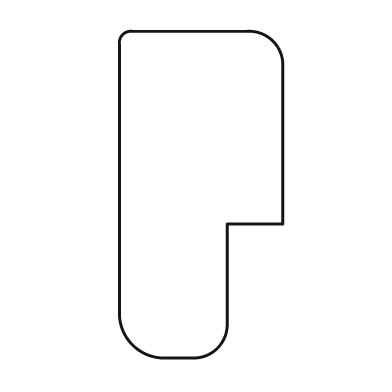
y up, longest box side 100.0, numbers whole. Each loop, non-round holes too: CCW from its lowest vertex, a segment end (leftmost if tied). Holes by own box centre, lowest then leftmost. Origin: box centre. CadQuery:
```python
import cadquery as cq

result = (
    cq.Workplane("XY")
    .moveTo(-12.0, -50.0)
    .lineTo(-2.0, -50.0)
    .threePointArc((5.0, -47.0), (8.0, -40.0))
    .lineTo(8.0, -9.0)
    .lineTo(25.0, -9.0)
    .lineTo(25.0, 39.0)
    .threePointArc((22.0, 47.0), (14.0, 50.0))
    .lineTo(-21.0, 50.0)
    .threePointArc((-24.0, 49.0), (-25.0, 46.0))
    .lineTo(-25.0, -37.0)
    .threePointArc((-21.0, -46.0), (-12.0, -50.0))
    .close()
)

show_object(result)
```